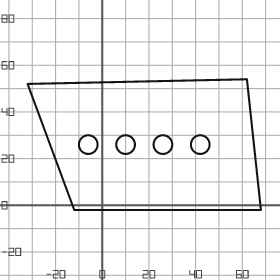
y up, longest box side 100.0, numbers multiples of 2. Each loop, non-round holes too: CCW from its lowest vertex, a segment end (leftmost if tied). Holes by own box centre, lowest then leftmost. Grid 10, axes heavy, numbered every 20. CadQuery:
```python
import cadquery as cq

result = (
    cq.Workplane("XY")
    .moveTo(-12.0, -2.0)
    .lineTo(68.0, -2.0)
    .lineTo(62.0, 54.0)
    .lineTo(-32.0, 52.0)
    .close()
    .moveTo(-6.0, 26.0)
    .circle(4.0)
    .moveTo(10.0, 26.0)
    .circle(4.0)
    .moveTo(26.0, 26.0)
    .circle(4.0)
    .moveTo(42.0, 26.0)
    .circle(4.0)
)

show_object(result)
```